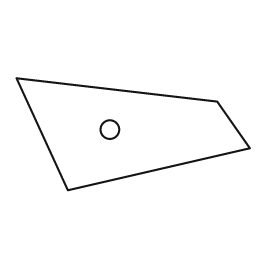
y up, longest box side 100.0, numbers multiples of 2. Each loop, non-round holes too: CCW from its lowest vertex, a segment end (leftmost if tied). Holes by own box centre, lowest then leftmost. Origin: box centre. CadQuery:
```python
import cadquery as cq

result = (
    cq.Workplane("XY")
    .moveTo(-28.0, -24.0)
    .lineTo(50.0, -6.0)
    .lineTo(36.0, 14.0)
    .lineTo(-50.0, 24.0)
    .close()
    .moveTo(-10.0, 2.0)
    .circle(4.0)
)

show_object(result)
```